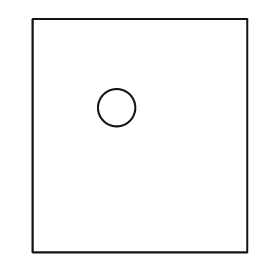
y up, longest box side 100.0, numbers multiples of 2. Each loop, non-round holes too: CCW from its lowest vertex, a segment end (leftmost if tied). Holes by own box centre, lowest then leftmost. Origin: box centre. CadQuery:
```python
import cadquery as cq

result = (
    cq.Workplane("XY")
    .moveTo(-46.0, -50.0)
    .lineTo(46.0, -50.0)
    .lineTo(46.0, 50.0)
    .lineTo(-46.0, 50.0)
    .close()
    .moveTo(-10.0, 12.0)
    .circle(8.0)
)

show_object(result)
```